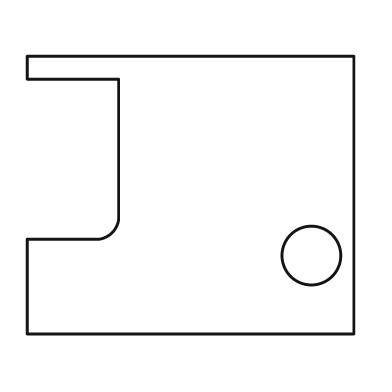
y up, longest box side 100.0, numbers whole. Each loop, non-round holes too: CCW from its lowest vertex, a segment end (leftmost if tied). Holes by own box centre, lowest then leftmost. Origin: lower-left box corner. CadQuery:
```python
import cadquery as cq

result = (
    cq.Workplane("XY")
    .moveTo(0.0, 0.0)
    .lineTo(100.0, 0.0)
    .lineTo(100.0, 85.0)
    .lineTo(0.0, 85.0)
    .lineTo(0.0, 78.0)
    .lineTo(28.0, 78.0)
    .lineTo(28.0, 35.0)
    .threePointArc((26.0, 31.0), (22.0, 29.0))
    .lineTo(0.0, 29.0)
    .close()
    .moveTo(87.0, 24.0)
    .circle(9.0)
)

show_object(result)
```